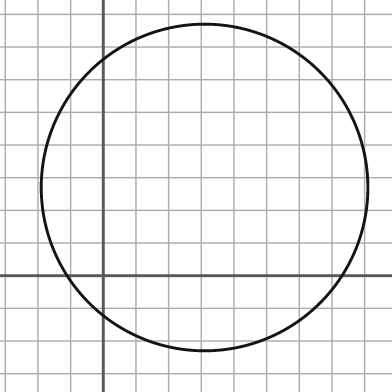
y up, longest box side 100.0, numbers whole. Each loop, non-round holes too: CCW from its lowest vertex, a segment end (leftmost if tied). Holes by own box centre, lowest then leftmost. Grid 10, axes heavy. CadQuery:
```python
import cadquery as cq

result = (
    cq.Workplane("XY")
    .moveTo(31.0, 27.0)
    .circle(50.0)
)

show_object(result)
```